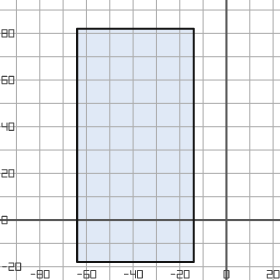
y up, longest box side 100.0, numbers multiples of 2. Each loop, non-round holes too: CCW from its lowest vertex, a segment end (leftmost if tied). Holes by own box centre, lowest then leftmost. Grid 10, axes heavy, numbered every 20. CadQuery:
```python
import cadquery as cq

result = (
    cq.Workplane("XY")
    .moveTo(-64.0, -18.0)
    .lineTo(-14.0, -18.0)
    .lineTo(-14.0, 82.0)
    .lineTo(-64.0, 82.0)
    .close()
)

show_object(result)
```